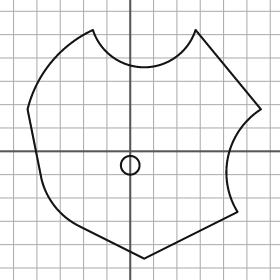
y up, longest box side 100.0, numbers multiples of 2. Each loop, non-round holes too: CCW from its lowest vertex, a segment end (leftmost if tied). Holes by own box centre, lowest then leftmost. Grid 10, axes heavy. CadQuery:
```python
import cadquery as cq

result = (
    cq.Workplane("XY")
    .moveTo(6.0, -46.0)
    .lineTo(46.0, -26.0)
    .threePointArc((42.0, -2.0), (56.0, 18.0))
    .lineTo(28.0, 52.0)
    .threePointArc((6.0, 36.0), (-16.0, 52.0))
    .threePointArc((-34.0, 38.0), (-44.0, 18.0))
    .lineTo(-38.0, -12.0)
    .threePointArc((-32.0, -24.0), (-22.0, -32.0))
    .close()
    .moveTo(0.0, -6.0)
    .circle(4.0)
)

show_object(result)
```